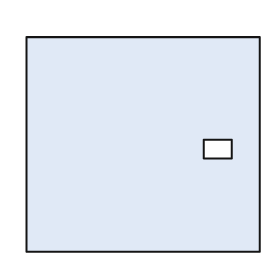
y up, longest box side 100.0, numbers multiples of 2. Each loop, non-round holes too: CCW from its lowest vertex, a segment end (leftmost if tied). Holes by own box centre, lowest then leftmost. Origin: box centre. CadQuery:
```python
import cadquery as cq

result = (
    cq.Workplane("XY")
    .moveTo(-50.0, -46.0)
    .lineTo(50.0, -46.0)
    .lineTo(50.0, 46.0)
    .lineTo(-50.0, 46.0)
    .close()
    .moveTo(26.0, -6.0)
    .lineTo(38.0, -6.0)
    .lineTo(38.0, 2.0)
    .lineTo(26.0, 2.0)
    .close()
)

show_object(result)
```